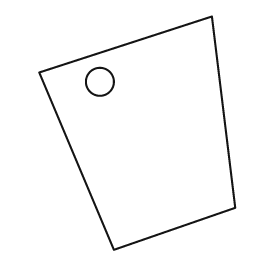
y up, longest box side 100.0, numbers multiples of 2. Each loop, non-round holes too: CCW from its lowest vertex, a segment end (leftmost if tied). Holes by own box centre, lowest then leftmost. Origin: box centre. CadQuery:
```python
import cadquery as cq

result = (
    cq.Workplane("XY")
    .moveTo(-10.0, -50.0)
    .lineTo(42.0, -32.0)
    .lineTo(32.0, 50.0)
    .lineTo(-42.0, 26.0)
    .close()
    .moveTo(-16.0, 22.0)
    .circle(6.0)
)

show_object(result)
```